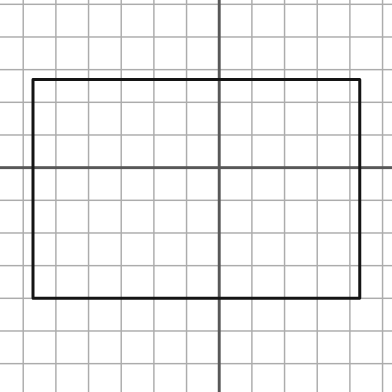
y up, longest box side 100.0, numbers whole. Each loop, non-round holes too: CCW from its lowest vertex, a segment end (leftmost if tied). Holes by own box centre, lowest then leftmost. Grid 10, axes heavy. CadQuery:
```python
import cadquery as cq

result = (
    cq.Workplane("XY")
    .moveTo(-57.0, -40.0)
    .lineTo(43.0, -40.0)
    .lineTo(43.0, 27.0)
    .lineTo(-57.0, 27.0)
    .close()
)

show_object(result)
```